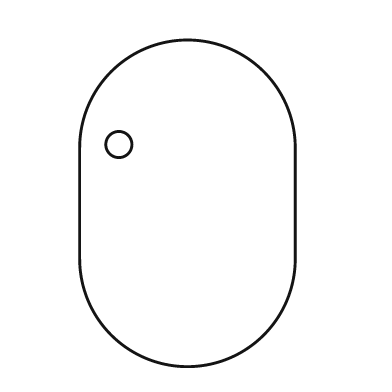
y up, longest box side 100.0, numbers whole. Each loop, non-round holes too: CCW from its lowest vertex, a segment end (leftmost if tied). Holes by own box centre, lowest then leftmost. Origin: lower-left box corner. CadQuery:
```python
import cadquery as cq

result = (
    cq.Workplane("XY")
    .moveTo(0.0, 33.0)
    .threePointArc((33.0, 0.0), (66.0, 33.0))
    .lineTo(66.0, 67.0)
    .threePointArc((33.0, 100.0), (0.0, 67.0))
    .close()
    .moveTo(12.0, 68.0)
    .circle(4.0)
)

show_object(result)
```